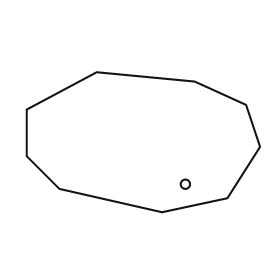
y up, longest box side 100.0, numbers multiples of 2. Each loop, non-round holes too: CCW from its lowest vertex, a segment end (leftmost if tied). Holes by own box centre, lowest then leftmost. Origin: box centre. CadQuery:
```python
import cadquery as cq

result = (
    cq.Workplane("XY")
    .moveTo(8.0, -30.0)
    .lineTo(36.0, -24.0)
    .lineTo(50.0, -2.0)
    .lineTo(44.0, 16.0)
    .lineTo(22.0, 26.0)
    .lineTo(-20.0, 30.0)
    .lineTo(-50.0, 14.0)
    .lineTo(-50.0, -6.0)
    .lineTo(-36.0, -20.0)
    .close()
    .moveTo(18.0, -18.0)
    .circle(2.0)
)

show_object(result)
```